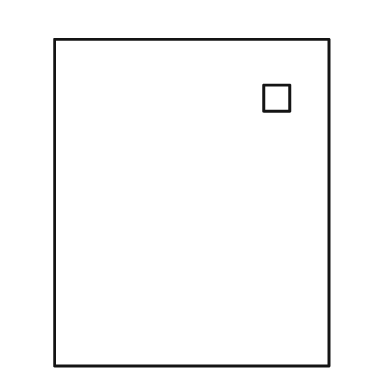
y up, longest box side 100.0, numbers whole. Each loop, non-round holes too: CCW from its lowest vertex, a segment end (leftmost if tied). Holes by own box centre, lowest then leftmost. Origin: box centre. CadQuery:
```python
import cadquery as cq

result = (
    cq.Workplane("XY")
    .moveTo(-42.0, -50.0)
    .lineTo(42.0, -50.0)
    .lineTo(42.0, 50.0)
    .lineTo(-42.0, 50.0)
    .close()
    .moveTo(22.0, 28.0)
    .lineTo(30.0, 28.0)
    .lineTo(30.0, 36.0)
    .lineTo(22.0, 36.0)
    .close()
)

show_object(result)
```